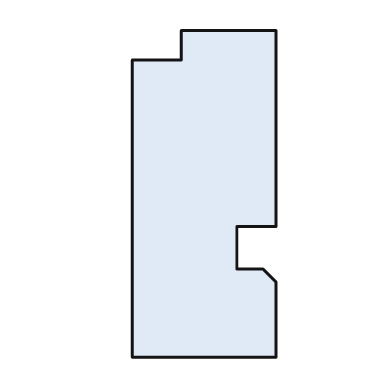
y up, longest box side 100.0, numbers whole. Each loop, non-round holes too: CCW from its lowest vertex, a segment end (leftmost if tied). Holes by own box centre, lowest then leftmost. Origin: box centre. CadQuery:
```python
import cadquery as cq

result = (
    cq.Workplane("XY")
    .moveTo(-22.0, -50.0)
    .lineTo(22.0, -50.0)
    .lineTo(22.0, -27.0)
    .lineTo(18.0, -23.0)
    .lineTo(10.0, -23.0)
    .lineTo(10.0, -10.0)
    .lineTo(22.0, -10.0)
    .lineTo(22.0, 50.0)
    .lineTo(-7.0, 50.0)
    .lineTo(-7.0, 41.0)
    .lineTo(-22.0, 41.0)
    .close()
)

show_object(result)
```